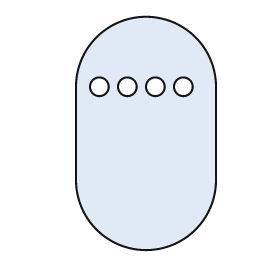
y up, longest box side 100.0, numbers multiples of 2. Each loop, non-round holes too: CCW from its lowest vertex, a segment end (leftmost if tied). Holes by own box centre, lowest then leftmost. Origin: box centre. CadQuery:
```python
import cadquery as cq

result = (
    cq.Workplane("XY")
    .moveTo(-30.0, -20.0)
    .threePointArc((0.0, -50.0), (30.0, -20.0))
    .lineTo(30.0, 20.0)
    .threePointArc((0.0, 50.0), (-30.0, 20.0))
    .close()
    .moveTo(-20.0, 20.0)
    .circle(4.0)
    .moveTo(-8.0, 20.0)
    .circle(4.0)
    .moveTo(4.0, 20.0)
    .circle(4.0)
    .moveTo(16.0, 20.0)
    .circle(4.0)
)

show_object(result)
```